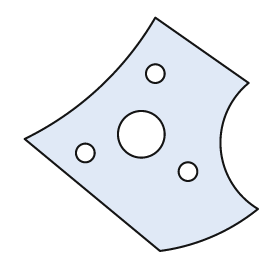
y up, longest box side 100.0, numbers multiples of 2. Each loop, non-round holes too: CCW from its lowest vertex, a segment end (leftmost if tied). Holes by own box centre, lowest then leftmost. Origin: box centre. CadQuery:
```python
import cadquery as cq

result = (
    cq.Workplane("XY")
    .moveTo(8.0, -50.0)
    .threePointArc((30.0, -44.0), (50.0, -32.0))
    .threePointArc((34.0, -6.0), (46.0, 22.0))
    .lineTo(6.0, 50.0)
    .threePointArc((-18.0, 20.0), (-50.0, -2.0))
    .close()
    .moveTo(20.0, -16.0)
    .circle(4.0)
    .moveTo(-24.0, -8.0)
    .circle(4.0)
    .moveTo(0.0, 0.0)
    .circle(10.0)
    .moveTo(6.0, 26.0)
    .circle(4.0)
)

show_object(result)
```